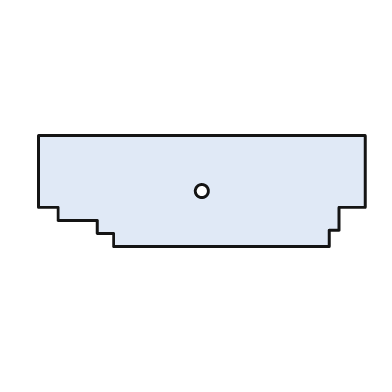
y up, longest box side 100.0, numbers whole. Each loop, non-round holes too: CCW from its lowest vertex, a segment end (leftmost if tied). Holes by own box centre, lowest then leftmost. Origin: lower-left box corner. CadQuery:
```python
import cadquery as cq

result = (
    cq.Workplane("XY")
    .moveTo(23.0, 0.0)
    .lineTo(89.0, 0.0)
    .lineTo(89.0, 5.0)
    .lineTo(92.0, 5.0)
    .lineTo(92.0, 12.0)
    .lineTo(100.0, 12.0)
    .lineTo(100.0, 34.0)
    .lineTo(0.0, 34.0)
    .lineTo(0.0, 12.0)
    .lineTo(6.0, 12.0)
    .lineTo(6.0, 8.0)
    .lineTo(18.0, 8.0)
    .lineTo(18.0, 4.0)
    .lineTo(23.0, 4.0)
    .close()
    .moveTo(50.0, 17.0)
    .circle(2.0)
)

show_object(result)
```